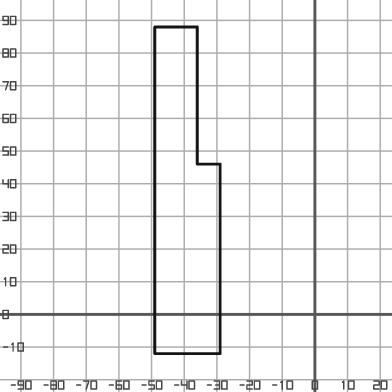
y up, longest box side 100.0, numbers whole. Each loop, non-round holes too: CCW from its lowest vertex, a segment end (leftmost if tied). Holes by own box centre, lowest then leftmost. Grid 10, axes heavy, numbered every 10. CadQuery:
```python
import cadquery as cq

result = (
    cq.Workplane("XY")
    .moveTo(-49.0, -12.0)
    .lineTo(-29.0, -12.0)
    .lineTo(-29.0, 46.0)
    .lineTo(-36.0, 46.0)
    .lineTo(-36.0, 88.0)
    .lineTo(-49.0, 88.0)
    .close()
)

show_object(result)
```